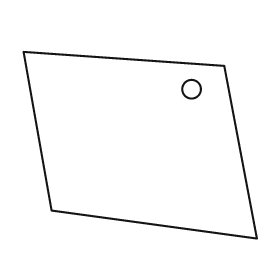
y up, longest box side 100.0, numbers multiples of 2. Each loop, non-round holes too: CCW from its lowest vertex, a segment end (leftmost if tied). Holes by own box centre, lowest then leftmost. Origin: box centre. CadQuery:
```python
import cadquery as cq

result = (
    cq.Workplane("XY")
    .moveTo(50.0, -40.0)
    .lineTo(36.0, 34.0)
    .lineTo(-50.0, 40.0)
    .lineTo(-38.0, -28.0)
    .close()
    .moveTo(22.0, 24.0)
    .circle(4.0)
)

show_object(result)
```